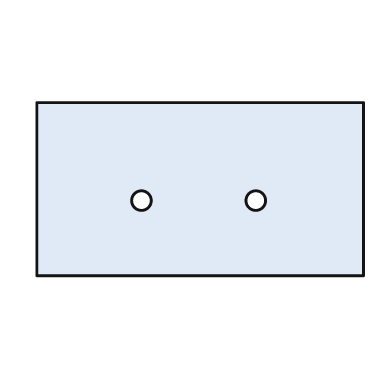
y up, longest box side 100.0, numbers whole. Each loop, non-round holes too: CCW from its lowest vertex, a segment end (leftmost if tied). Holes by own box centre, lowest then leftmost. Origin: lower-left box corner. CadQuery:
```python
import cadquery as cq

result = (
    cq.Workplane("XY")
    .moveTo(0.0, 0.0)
    .lineTo(100.0, 0.0)
    .lineTo(100.0, 53.0)
    .lineTo(0.0, 53.0)
    .close()
    .moveTo(32.0, 23.0)
    .circle(3.0)
    .moveTo(67.0, 23.0)
    .circle(3.0)
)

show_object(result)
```